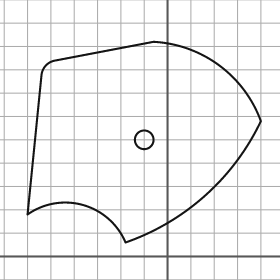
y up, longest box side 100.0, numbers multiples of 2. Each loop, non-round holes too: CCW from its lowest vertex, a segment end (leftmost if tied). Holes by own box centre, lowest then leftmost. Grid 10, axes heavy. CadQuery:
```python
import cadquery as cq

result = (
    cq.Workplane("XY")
    .moveTo(-18.0, 6.0)
    .threePointArc((16.0, 26.0), (40.0, 58.0))
    .threePointArc((22.0, 82.0), (-6.0, 92.0))
    .lineTo(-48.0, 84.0)
    .threePointArc((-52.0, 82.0), (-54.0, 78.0))
    .lineTo(-60.0, 18.0)
    .threePointArc((-36.0, 22.0), (-18.0, 6.0))
    .close()
    .moveTo(-10.0, 50.0)
    .circle(4.0)
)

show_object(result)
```